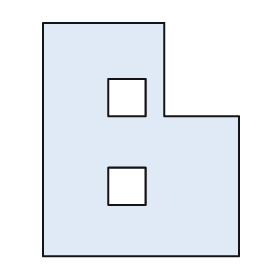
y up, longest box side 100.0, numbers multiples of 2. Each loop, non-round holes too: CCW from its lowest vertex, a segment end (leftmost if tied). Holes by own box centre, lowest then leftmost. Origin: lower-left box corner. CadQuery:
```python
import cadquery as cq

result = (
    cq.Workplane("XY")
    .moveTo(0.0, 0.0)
    .lineTo(84.0, 0.0)
    .lineTo(84.0, 60.0)
    .lineTo(52.0, 60.0)
    .lineTo(52.0, 100.0)
    .lineTo(0.0, 100.0)
    .close()
    .moveTo(28.0, 22.0)
    .lineTo(44.0, 22.0)
    .lineTo(44.0, 38.0)
    .lineTo(28.0, 38.0)
    .close()
    .moveTo(28.0, 60.0)
    .lineTo(44.0, 60.0)
    .lineTo(44.0, 76.0)
    .lineTo(28.0, 76.0)
    .close()
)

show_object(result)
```